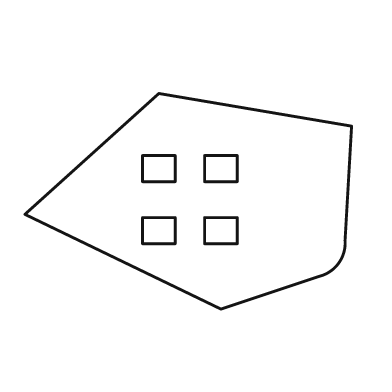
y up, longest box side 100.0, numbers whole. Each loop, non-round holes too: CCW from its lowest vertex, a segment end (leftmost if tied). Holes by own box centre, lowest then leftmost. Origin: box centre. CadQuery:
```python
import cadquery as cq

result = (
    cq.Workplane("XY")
    .moveTo(10.0, -33.0)
    .lineTo(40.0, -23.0)
    .threePointArc((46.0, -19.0), (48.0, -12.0))
    .lineTo(50.0, 23.0)
    .lineTo(-9.0, 33.0)
    .lineTo(-50.0, -4.0)
    .close()
    .moveTo(-14.0, -13.0)
    .lineTo(-4.0, -13.0)
    .lineTo(-4.0, -5.0)
    .lineTo(-14.0, -5.0)
    .close()
    .moveTo(5.0, -13.0)
    .lineTo(15.0, -13.0)
    .lineTo(15.0, -5.0)
    .lineTo(5.0, -5.0)
    .close()
    .moveTo(-14.0, 6.0)
    .lineTo(-4.0, 6.0)
    .lineTo(-4.0, 14.0)
    .lineTo(-14.0, 14.0)
    .close()
    .moveTo(5.0, 6.0)
    .lineTo(15.0, 6.0)
    .lineTo(15.0, 14.0)
    .lineTo(5.0, 14.0)
    .close()
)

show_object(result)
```